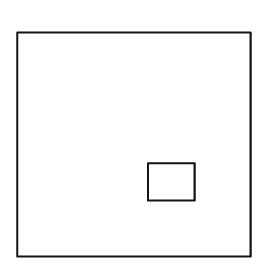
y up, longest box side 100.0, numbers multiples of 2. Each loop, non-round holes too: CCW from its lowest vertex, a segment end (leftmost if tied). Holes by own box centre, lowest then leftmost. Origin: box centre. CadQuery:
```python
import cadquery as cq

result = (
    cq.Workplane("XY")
    .moveTo(-50.0, -48.0)
    .lineTo(50.0, -48.0)
    .lineTo(50.0, 48.0)
    .lineTo(-50.0, 48.0)
    .close()
    .moveTo(6.0, -24.0)
    .lineTo(26.0, -24.0)
    .lineTo(26.0, -8.0)
    .lineTo(6.0, -8.0)
    .close()
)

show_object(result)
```